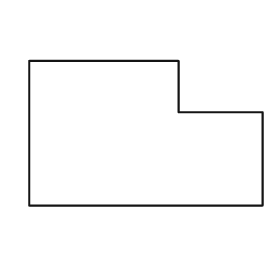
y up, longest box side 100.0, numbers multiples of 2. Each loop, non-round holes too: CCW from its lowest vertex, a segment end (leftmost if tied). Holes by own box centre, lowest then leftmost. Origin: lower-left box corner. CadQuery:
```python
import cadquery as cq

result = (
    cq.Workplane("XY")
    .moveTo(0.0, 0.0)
    .lineTo(100.0, 0.0)
    .lineTo(100.0, 40.0)
    .lineTo(64.0, 40.0)
    .lineTo(64.0, 62.0)
    .lineTo(0.0, 62.0)
    .close()
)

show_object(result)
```